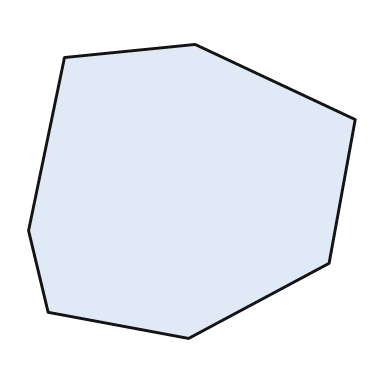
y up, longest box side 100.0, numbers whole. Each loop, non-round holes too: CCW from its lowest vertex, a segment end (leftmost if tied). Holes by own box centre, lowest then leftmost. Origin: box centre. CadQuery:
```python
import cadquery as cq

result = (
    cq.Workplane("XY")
    .moveTo(-1.0, -45.0)
    .lineTo(42.0, -22.0)
    .lineTo(50.0, 22.0)
    .lineTo(1.0, 45.0)
    .lineTo(-39.0, 41.0)
    .lineTo(-50.0, -12.0)
    .lineTo(-44.0, -37.0)
    .close()
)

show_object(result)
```